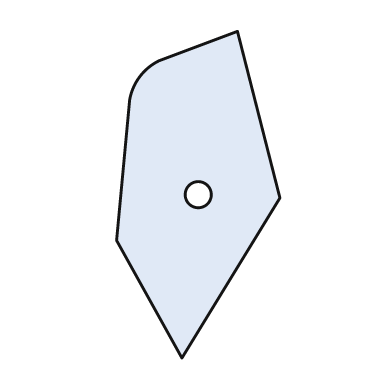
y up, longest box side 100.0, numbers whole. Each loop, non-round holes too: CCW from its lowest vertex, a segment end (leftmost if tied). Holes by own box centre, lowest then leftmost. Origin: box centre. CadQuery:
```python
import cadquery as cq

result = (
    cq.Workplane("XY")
    .moveTo(-5.0, -50.0)
    .lineTo(25.0, -1.0)
    .lineTo(12.0, 50.0)
    .lineTo(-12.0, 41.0)
    .threePointArc((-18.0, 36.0), (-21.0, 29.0))
    .lineTo(-25.0, -14.0)
    .close()
    .moveTo(0.0, 0.0)
    .circle(4.0)
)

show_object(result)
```